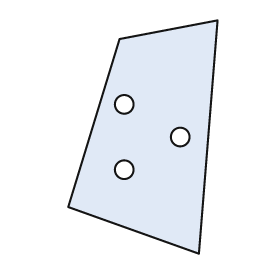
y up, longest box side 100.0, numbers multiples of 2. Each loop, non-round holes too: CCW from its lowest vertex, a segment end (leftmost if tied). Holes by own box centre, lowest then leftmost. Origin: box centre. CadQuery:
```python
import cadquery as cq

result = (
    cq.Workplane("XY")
    .moveTo(24.0, -50.0)
    .lineTo(32.0, 50.0)
    .lineTo(-10.0, 42.0)
    .lineTo(-32.0, -30.0)
    .close()
    .moveTo(-8.0, -14.0)
    .circle(4.0)
    .moveTo(16.0, 0.0)
    .circle(4.0)
    .moveTo(-8.0, 14.0)
    .circle(4.0)
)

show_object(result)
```